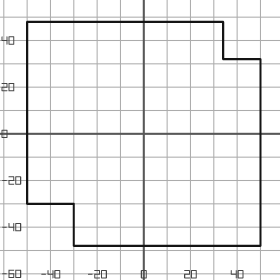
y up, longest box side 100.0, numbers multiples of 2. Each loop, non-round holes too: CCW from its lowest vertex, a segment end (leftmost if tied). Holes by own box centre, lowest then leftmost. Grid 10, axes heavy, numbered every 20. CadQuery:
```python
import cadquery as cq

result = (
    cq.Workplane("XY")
    .moveTo(-30.0, -48.0)
    .lineTo(50.0, -48.0)
    .lineTo(50.0, 32.0)
    .lineTo(34.0, 32.0)
    .lineTo(34.0, 48.0)
    .lineTo(-50.0, 48.0)
    .lineTo(-50.0, -30.0)
    .lineTo(-30.0, -30.0)
    .close()
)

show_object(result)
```